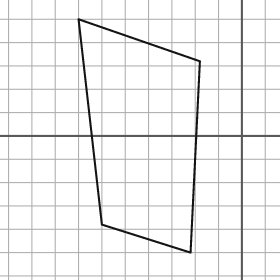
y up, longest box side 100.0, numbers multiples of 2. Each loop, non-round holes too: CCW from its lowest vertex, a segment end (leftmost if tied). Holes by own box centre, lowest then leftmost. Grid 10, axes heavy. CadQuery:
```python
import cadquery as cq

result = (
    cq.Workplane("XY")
    .moveTo(-22.0, -50.0)
    .lineTo(-18.0, 32.0)
    .lineTo(-70.0, 50.0)
    .lineTo(-60.0, -38.0)
    .close()
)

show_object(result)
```